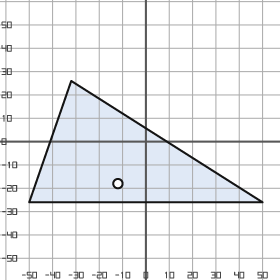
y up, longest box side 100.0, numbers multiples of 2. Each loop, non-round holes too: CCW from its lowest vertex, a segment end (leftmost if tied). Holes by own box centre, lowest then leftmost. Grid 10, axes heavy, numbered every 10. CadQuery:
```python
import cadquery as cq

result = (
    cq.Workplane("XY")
    .moveTo(-50.0, -26.0)
    .lineTo(50.0, -26.0)
    .lineTo(-32.0, 26.0)
    .close()
    .moveTo(-12.0, -18.0)
    .circle(2.0)
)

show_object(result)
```